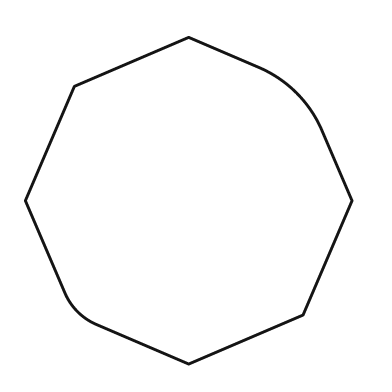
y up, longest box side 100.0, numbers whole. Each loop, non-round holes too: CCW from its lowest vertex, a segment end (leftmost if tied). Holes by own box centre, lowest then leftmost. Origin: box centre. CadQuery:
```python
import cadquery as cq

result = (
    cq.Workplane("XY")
    .moveTo(0.0, -50.0)
    .lineTo(35.0, -35.0)
    .lineTo(50.0, 0.0)
    .lineTo(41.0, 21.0)
    .threePointArc((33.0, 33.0), (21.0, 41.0))
    .lineTo(0.0, 50.0)
    .lineTo(-35.0, 35.0)
    .lineTo(-50.0, 0.0)
    .lineTo(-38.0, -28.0)
    .threePointArc((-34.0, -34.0), (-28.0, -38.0))
    .close()
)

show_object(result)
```